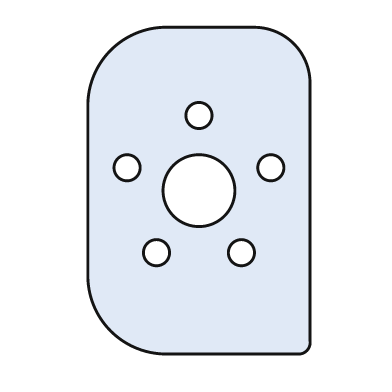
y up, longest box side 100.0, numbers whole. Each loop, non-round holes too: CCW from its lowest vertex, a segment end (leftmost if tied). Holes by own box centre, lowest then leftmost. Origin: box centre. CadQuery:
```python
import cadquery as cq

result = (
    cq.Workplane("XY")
    .moveTo(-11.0, -50.0)
    .lineTo(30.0, -50.0)
    .threePointArc((33.0, -49.0), (34.0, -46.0))
    .lineTo(34.0, 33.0)
    .threePointArc((29.0, 45.0), (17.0, 50.0))
    .lineTo(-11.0, 50.0)
    .threePointArc((-27.0, 43.0), (-34.0, 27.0))
    .lineTo(-34.0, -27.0)
    .threePointArc((-27.0, -43.0), (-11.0, -50.0))
    .close()
    .moveTo(-13.0, -19.0)
    .circle(4.0)
    .moveTo(13.0, -19.0)
    .circle(4.0)
    .moveTo(0.0, 0.0)
    .circle(11.0)
    .moveTo(-22.0, 7.0)
    .circle(4.0)
    .moveTo(22.0, 7.0)
    .circle(4.0)
    .moveTo(0.0, 23.0)
    .circle(4.0)
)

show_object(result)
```